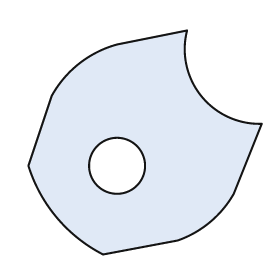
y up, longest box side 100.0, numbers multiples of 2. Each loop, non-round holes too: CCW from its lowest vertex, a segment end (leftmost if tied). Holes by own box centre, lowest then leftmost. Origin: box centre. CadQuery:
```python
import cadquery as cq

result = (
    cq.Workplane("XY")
    .moveTo(-18.0, -48.0)
    .lineTo(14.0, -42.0)
    .threePointArc((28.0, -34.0), (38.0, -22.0))
    .lineTo(50.0, 8.0)
    .threePointArc((24.0, 20.0), (18.0, 48.0))
    .lineTo(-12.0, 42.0)
    .threePointArc((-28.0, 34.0), (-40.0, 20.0))
    .lineTo(-50.0, -10.0)
    .threePointArc((-38.0, -32.0), (-18.0, -48.0))
    .close()
    .moveTo(-12.0, -10.0)
    .circle(12.0)
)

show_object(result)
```